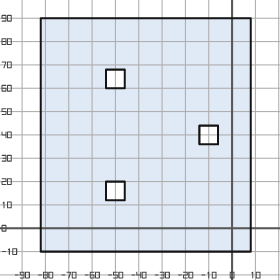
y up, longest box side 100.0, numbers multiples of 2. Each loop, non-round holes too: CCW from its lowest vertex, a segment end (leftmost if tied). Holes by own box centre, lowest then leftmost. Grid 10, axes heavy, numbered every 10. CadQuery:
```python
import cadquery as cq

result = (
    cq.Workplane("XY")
    .moveTo(-82.0, -10.0)
    .lineTo(8.0, -10.0)
    .lineTo(8.0, 90.0)
    .lineTo(-82.0, 90.0)
    .close()
    .moveTo(-54.0, 12.0)
    .lineTo(-46.0, 12.0)
    .lineTo(-46.0, 20.0)
    .lineTo(-54.0, 20.0)
    .close()
    .moveTo(-14.0, 36.0)
    .lineTo(-6.0, 36.0)
    .lineTo(-6.0, 44.0)
    .lineTo(-14.0, 44.0)
    .close()
    .moveTo(-54.0, 60.0)
    .lineTo(-46.0, 60.0)
    .lineTo(-46.0, 68.0)
    .lineTo(-54.0, 68.0)
    .close()
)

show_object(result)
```